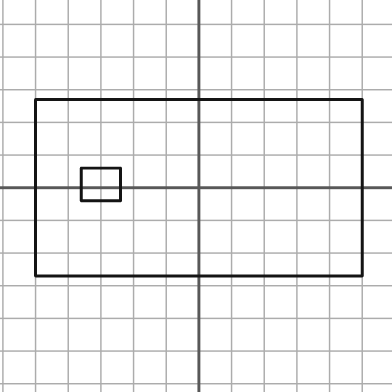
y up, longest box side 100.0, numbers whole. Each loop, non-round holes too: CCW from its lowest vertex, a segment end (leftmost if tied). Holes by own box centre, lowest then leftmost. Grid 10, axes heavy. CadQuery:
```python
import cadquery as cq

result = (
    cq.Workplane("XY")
    .moveTo(-50.0, -27.0)
    .lineTo(50.0, -27.0)
    .lineTo(50.0, 27.0)
    .lineTo(-50.0, 27.0)
    .close()
    .moveTo(-36.0, -4.0)
    .lineTo(-24.0, -4.0)
    .lineTo(-24.0, 6.0)
    .lineTo(-36.0, 6.0)
    .close()
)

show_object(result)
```